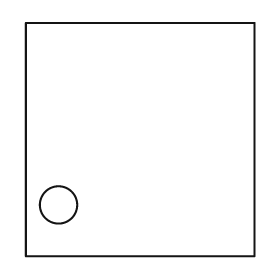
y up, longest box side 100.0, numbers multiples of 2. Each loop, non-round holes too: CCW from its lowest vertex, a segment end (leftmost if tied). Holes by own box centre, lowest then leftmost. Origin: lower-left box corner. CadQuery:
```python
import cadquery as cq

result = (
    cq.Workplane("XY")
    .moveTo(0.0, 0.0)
    .lineTo(98.0, 0.0)
    .lineTo(98.0, 100.0)
    .lineTo(0.0, 100.0)
    .close()
    .moveTo(14.0, 22.0)
    .circle(8.0)
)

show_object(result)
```